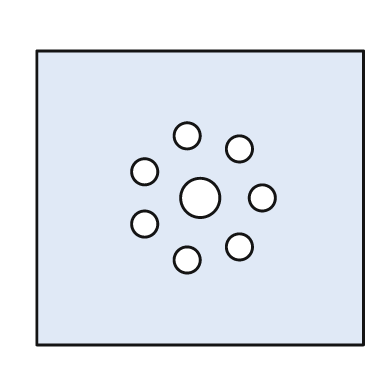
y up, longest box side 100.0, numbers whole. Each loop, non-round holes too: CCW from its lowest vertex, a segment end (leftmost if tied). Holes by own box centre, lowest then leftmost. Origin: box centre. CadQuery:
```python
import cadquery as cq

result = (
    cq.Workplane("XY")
    .moveTo(-50.0, -45.0)
    .lineTo(50.0, -45.0)
    .lineTo(50.0, 45.0)
    .lineTo(-50.0, 45.0)
    .close()
    .moveTo(-4.0, -19.0)
    .circle(4.0)
    .moveTo(12.0, -15.0)
    .circle(4.0)
    .moveTo(-17.0, -8.0)
    .circle(4.0)
    .moveTo(0.0, 0.0)
    .circle(6.0)
    .moveTo(19.0, 0.0)
    .circle(4.0)
    .moveTo(-17.0, 8.0)
    .circle(4.0)
    .moveTo(12.0, 15.0)
    .circle(4.0)
    .moveTo(-4.0, 19.0)
    .circle(4.0)
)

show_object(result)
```